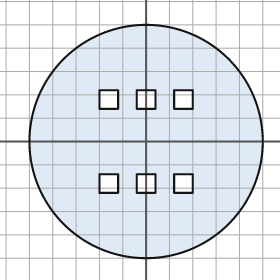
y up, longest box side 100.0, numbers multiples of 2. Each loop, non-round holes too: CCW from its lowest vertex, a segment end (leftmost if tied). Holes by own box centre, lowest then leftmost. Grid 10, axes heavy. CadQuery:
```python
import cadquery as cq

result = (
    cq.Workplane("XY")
    .moveTo(0.0, 0.0)
    .circle(50.0)
    .moveTo(-20.0, -22.0)
    .lineTo(-12.0, -22.0)
    .lineTo(-12.0, -14.0)
    .lineTo(-20.0, -14.0)
    .close()
    .moveTo(-4.0, -22.0)
    .lineTo(4.0, -22.0)
    .lineTo(4.0, -14.0)
    .lineTo(-4.0, -14.0)
    .close()
    .moveTo(12.0, -22.0)
    .lineTo(20.0, -22.0)
    .lineTo(20.0, -14.0)
    .lineTo(12.0, -14.0)
    .close()
    .moveTo(-20.0, 14.0)
    .lineTo(-12.0, 14.0)
    .lineTo(-12.0, 22.0)
    .lineTo(-20.0, 22.0)
    .close()
    .moveTo(-4.0, 14.0)
    .lineTo(4.0, 14.0)
    .lineTo(4.0, 22.0)
    .lineTo(-4.0, 22.0)
    .close()
    .moveTo(12.0, 14.0)
    .lineTo(20.0, 14.0)
    .lineTo(20.0, 22.0)
    .lineTo(12.0, 22.0)
    .close()
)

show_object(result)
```